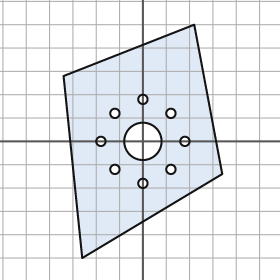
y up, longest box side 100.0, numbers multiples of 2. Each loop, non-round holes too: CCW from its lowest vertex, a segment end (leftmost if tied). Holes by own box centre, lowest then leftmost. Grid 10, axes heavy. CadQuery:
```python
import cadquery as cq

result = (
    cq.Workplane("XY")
    .moveTo(-26.0, -50.0)
    .lineTo(34.0, -14.0)
    .lineTo(22.0, 50.0)
    .lineTo(-34.0, 28.0)
    .close()
    .moveTo(0.0, -18.0)
    .circle(2.0)
    .moveTo(-12.0, -12.0)
    .circle(2.0)
    .moveTo(12.0, -12.0)
    .circle(2.0)
    .moveTo(-18.0, 0.0)
    .circle(2.0)
    .moveTo(0.0, 0.0)
    .circle(8.0)
    .moveTo(18.0, 0.0)
    .circle(2.0)
    .moveTo(-12.0, 12.0)
    .circle(2.0)
    .moveTo(12.0, 12.0)
    .circle(2.0)
    .moveTo(0.0, 18.0)
    .circle(2.0)
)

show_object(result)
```